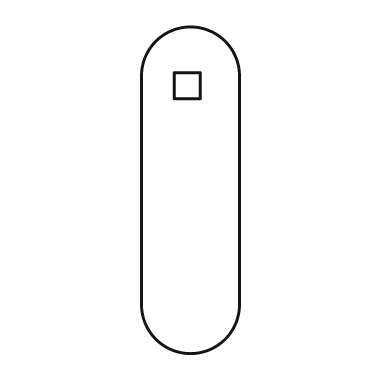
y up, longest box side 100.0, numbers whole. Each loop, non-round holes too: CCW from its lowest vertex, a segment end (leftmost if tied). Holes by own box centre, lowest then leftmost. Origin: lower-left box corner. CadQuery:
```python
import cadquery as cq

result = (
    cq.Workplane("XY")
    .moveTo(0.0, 15.0)
    .threePointArc((15.0, 0.0), (30.0, 15.0))
    .lineTo(30.0, 85.0)
    .threePointArc((15.0, 100.0), (0.0, 85.0))
    .close()
    .moveTo(10.0, 78.0)
    .lineTo(18.0, 78.0)
    .lineTo(18.0, 86.0)
    .lineTo(10.0, 86.0)
    .close()
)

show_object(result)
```